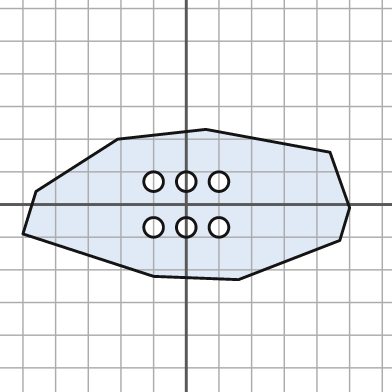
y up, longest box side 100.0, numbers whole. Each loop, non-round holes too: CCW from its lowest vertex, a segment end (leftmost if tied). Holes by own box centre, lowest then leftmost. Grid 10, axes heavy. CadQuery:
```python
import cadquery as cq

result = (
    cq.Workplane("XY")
    .moveTo(16.0, -23.0)
    .lineTo(47.0, -11.0)
    .lineTo(50.0, -1.0)
    .lineTo(44.0, 16.0)
    .lineTo(6.0, 23.0)
    .lineTo(-21.0, 20.0)
    .lineTo(-46.0, 4.0)
    .lineTo(-50.0, -9.0)
    .lineTo(-10.0, -22.0)
    .close()
    .moveTo(-10.0, -7.0)
    .circle(3.0)
    .moveTo(0.0, -7.0)
    .circle(3.0)
    .moveTo(10.0, -7.0)
    .circle(3.0)
    .moveTo(-10.0, 7.0)
    .circle(3.0)
    .moveTo(0.0, 7.0)
    .circle(3.0)
    .moveTo(10.0, 7.0)
    .circle(3.0)
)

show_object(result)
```